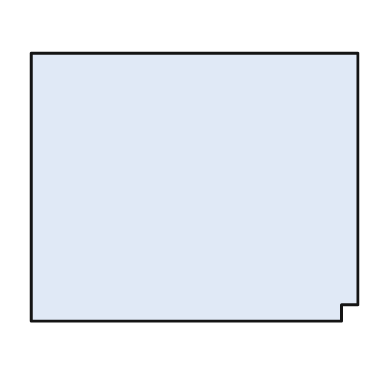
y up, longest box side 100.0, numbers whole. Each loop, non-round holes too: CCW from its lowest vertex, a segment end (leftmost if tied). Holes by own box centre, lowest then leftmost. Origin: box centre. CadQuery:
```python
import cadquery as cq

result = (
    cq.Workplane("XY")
    .moveTo(-50.0, -41.0)
    .lineTo(45.0, -41.0)
    .lineTo(45.0, -36.0)
    .lineTo(50.0, -36.0)
    .lineTo(50.0, 41.0)
    .lineTo(-50.0, 41.0)
    .close()
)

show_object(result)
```